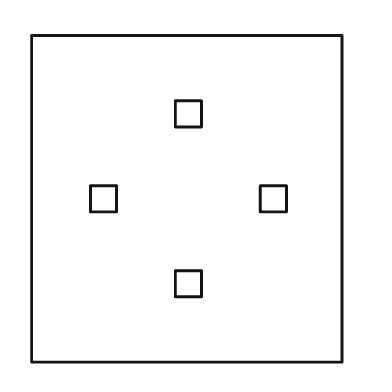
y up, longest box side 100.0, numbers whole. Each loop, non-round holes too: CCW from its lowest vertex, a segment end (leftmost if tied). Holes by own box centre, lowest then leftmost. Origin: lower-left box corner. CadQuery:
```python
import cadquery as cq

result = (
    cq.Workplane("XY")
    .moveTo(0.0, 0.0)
    .lineTo(95.0, 0.0)
    .lineTo(95.0, 100.0)
    .lineTo(0.0, 100.0)
    .close()
    .moveTo(44.0, 20.0)
    .lineTo(52.0, 20.0)
    .lineTo(52.0, 28.0)
    .lineTo(44.0, 28.0)
    .close()
    .moveTo(18.0, 46.0)
    .lineTo(26.0, 46.0)
    .lineTo(26.0, 54.0)
    .lineTo(18.0, 54.0)
    .close()
    .moveTo(70.0, 46.0)
    .lineTo(78.0, 46.0)
    .lineTo(78.0, 54.0)
    .lineTo(70.0, 54.0)
    .close()
    .moveTo(44.0, 72.0)
    .lineTo(52.0, 72.0)
    .lineTo(52.0, 80.0)
    .lineTo(44.0, 80.0)
    .close()
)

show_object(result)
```